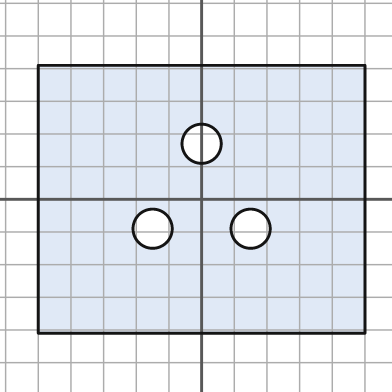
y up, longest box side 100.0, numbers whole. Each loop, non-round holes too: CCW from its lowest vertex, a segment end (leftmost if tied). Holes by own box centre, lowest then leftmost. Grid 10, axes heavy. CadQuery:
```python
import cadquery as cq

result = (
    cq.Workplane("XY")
    .moveTo(-50.0, -41.0)
    .lineTo(50.0, -41.0)
    .lineTo(50.0, 41.0)
    .lineTo(-50.0, 41.0)
    .close()
    .moveTo(-15.0, -9.0)
    .circle(6.0)
    .moveTo(15.0, -9.0)
    .circle(6.0)
    .moveTo(0.0, 17.0)
    .circle(6.0)
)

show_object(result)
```